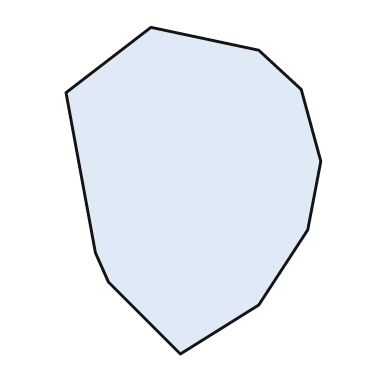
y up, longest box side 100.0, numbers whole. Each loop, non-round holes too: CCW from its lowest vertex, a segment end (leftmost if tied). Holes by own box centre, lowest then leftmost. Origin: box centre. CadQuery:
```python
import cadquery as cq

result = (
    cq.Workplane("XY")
    .moveTo(-4.0, -50.0)
    .lineTo(20.0, -35.0)
    .lineTo(35.0, -12.0)
    .lineTo(39.0, 9.0)
    .lineTo(33.0, 31.0)
    .lineTo(20.0, 43.0)
    .lineTo(-13.0, 50.0)
    .lineTo(-39.0, 30.0)
    .lineTo(-30.0, -19.0)
    .lineTo(-26.0, -28.0)
    .close()
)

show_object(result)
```